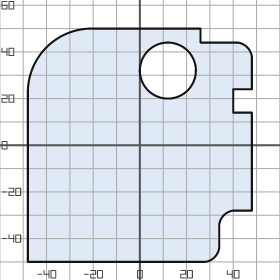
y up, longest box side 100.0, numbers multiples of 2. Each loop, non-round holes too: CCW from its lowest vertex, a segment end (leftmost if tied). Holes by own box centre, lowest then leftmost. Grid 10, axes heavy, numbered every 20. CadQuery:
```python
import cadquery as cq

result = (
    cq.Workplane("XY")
    .moveTo(-48.0, -50.0)
    .lineTo(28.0, -50.0)
    .threePointArc((32.0, -48.0), (34.0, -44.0))
    .lineTo(34.0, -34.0)
    .threePointArc((36.0, -30.0), (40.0, -28.0))
    .lineTo(48.0, -28.0)
    .lineTo(48.0, 14.0)
    .lineTo(40.0, 14.0)
    .lineTo(40.0, 24.0)
    .lineTo(48.0, 24.0)
    .lineTo(48.0, 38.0)
    .threePointArc((46.0, 42.0), (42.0, 44.0))
    .lineTo(26.0, 44.0)
    .lineTo(26.0, 50.0)
    .lineTo(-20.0, 50.0)
    .threePointArc((-40.0, 42.0), (-48.0, 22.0))
    .close()
    .moveTo(12.0, 32.0)
    .circle(12.0)
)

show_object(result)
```